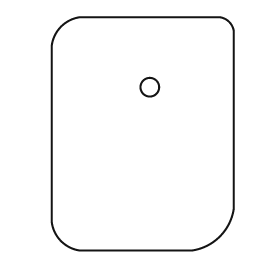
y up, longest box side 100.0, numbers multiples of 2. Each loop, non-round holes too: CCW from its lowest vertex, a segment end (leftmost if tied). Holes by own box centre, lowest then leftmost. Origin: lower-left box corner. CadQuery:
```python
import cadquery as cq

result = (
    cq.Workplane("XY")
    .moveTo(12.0, 0.0)
    .lineTo(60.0, 0.0)
    .threePointArc((72.0, 6.0), (78.0, 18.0))
    .lineTo(78.0, 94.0)
    .threePointArc((76.0, 98.0), (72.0, 100.0))
    .lineTo(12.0, 100.0)
    .threePointArc((4.0, 96.0), (0.0, 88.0))
    .lineTo(0.0, 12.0)
    .threePointArc((4.0, 4.0), (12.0, 0.0))
    .close()
    .moveTo(42.0, 70.0)
    .circle(4.0)
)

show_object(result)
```